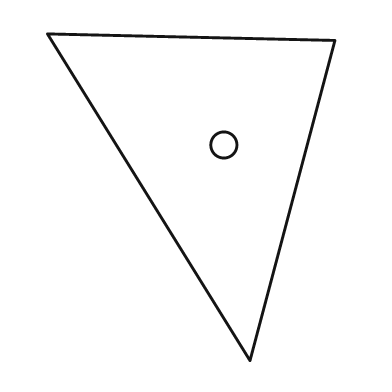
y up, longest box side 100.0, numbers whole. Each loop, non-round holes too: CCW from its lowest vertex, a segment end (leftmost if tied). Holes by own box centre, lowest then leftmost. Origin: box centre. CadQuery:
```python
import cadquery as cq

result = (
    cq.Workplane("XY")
    .moveTo(18.0, -50.0)
    .lineTo(44.0, 48.0)
    .lineTo(-44.0, 50.0)
    .close()
    .moveTo(10.0, 16.0)
    .circle(4.0)
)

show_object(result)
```